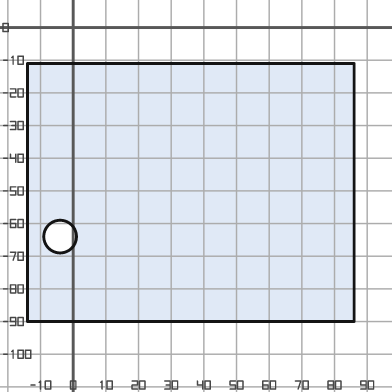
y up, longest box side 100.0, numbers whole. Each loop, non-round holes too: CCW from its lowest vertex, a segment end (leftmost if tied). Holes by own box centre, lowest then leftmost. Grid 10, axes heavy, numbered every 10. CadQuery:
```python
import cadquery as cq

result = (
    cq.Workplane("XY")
    .moveTo(-14.0, -90.0)
    .lineTo(86.0, -90.0)
    .lineTo(86.0, -11.0)
    .lineTo(-14.0, -11.0)
    .close()
    .moveTo(-4.0, -64.0)
    .circle(5.0)
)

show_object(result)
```